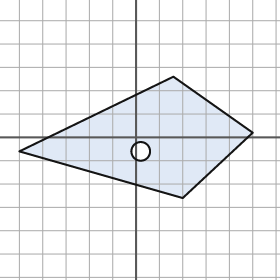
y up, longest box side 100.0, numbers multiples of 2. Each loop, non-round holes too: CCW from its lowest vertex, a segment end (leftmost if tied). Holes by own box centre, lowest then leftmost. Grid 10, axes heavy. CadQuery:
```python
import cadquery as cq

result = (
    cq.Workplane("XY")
    .moveTo(20.0, -26.0)
    .lineTo(50.0, 2.0)
    .lineTo(16.0, 26.0)
    .lineTo(-50.0, -6.0)
    .close()
    .moveTo(2.0, -6.0)
    .circle(4.0)
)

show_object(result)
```